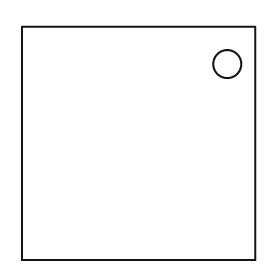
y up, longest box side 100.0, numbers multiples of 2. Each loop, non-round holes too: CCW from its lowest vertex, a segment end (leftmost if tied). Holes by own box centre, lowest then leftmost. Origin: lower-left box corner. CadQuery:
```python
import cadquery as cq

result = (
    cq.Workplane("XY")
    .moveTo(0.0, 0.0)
    .lineTo(100.0, 0.0)
    .lineTo(100.0, 100.0)
    .lineTo(0.0, 100.0)
    .close()
    .moveTo(88.0, 84.0)
    .circle(6.0)
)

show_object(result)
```